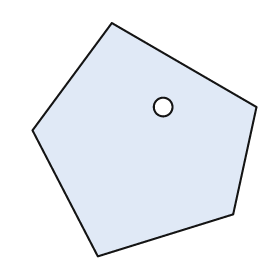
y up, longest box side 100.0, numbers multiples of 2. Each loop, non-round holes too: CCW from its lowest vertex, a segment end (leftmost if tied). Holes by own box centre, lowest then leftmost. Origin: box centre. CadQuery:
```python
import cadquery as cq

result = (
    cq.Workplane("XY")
    .moveTo(-20.0, -50.0)
    .lineTo(38.0, -32.0)
    .lineTo(48.0, 14.0)
    .lineTo(-14.0, 50.0)
    .lineTo(-48.0, 4.0)
    .close()
    .moveTo(8.0, 14.0)
    .circle(4.0)
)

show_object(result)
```